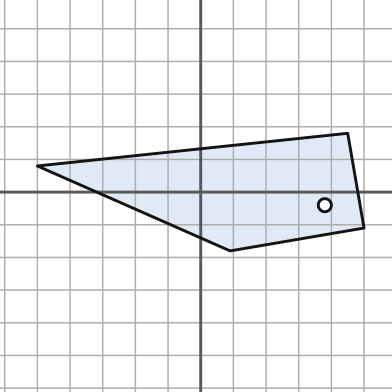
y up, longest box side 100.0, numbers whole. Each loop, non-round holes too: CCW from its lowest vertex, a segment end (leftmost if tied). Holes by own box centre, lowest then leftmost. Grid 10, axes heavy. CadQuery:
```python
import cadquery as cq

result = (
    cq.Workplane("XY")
    .moveTo(9.0, -18.0)
    .lineTo(50.0, -11.0)
    .lineTo(45.0, 18.0)
    .lineTo(-50.0, 8.0)
    .close()
    .moveTo(38.0, -4.0)
    .circle(2.0)
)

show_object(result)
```